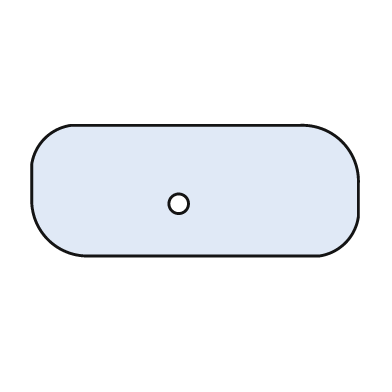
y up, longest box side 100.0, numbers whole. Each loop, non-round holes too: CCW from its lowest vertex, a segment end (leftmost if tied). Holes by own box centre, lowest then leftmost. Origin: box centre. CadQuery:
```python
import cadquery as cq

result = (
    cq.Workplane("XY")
    .moveTo(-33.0, -20.0)
    .lineTo(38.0, -20.0)
    .threePointArc((46.0, -16.0), (50.0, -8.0))
    .lineTo(50.0, 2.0)
    .threePointArc((45.0, 15.0), (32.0, 20.0))
    .lineTo(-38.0, 20.0)
    .threePointArc((-46.0, 16.0), (-50.0, 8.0))
    .lineTo(-50.0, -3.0)
    .threePointArc((-45.0, -15.0), (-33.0, -20.0))
    .close()
    .moveTo(-5.0, -4.0)
    .circle(3.0)
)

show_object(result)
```